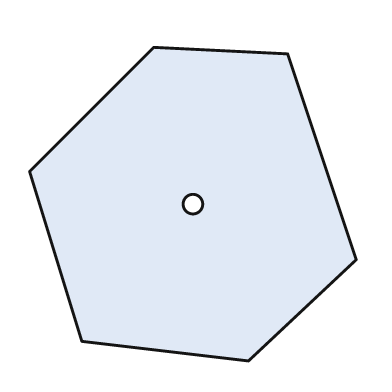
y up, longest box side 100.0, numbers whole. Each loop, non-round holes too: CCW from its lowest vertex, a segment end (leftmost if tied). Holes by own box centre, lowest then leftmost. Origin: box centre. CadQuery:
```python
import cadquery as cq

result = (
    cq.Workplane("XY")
    .moveTo(17.0, -48.0)
    .lineTo(50.0, -17.0)
    .lineTo(29.0, 46.0)
    .lineTo(-12.0, 48.0)
    .lineTo(-50.0, 10.0)
    .lineTo(-34.0, -42.0)
    .close()
    .moveTo(0.0, 0.0)
    .circle(3.0)
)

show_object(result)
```